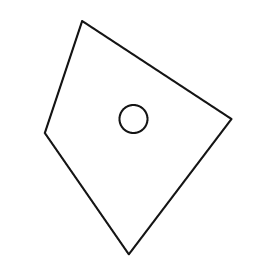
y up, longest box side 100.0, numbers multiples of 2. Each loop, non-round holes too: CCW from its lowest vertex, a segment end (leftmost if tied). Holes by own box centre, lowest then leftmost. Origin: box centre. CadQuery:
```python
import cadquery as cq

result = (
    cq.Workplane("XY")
    .moveTo(-4.0, -50.0)
    .lineTo(40.0, 8.0)
    .lineTo(-24.0, 50.0)
    .lineTo(-40.0, 2.0)
    .close()
    .moveTo(-2.0, 8.0)
    .circle(6.0)
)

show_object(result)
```